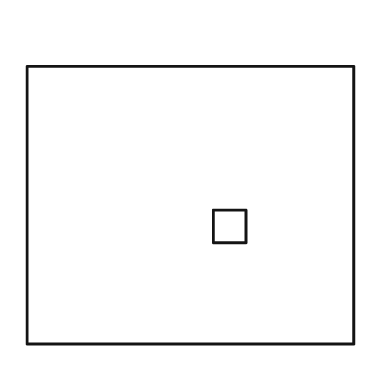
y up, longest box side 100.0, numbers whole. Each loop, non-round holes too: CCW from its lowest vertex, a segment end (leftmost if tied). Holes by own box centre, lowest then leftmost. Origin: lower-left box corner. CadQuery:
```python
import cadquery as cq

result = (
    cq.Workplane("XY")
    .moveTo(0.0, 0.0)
    .lineTo(100.0, 0.0)
    .lineTo(100.0, 85.0)
    .lineTo(0.0, 85.0)
    .close()
    .moveTo(57.0, 31.0)
    .lineTo(67.0, 31.0)
    .lineTo(67.0, 41.0)
    .lineTo(57.0, 41.0)
    .close()
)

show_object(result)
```